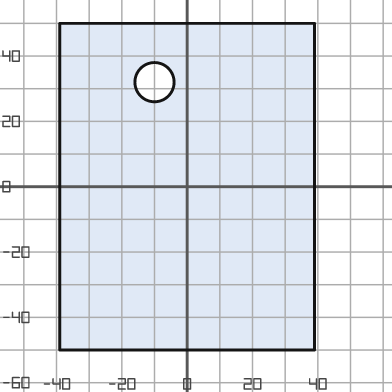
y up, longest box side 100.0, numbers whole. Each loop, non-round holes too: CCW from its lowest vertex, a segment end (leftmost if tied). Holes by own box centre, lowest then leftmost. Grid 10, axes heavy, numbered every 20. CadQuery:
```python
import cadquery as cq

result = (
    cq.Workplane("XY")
    .moveTo(-39.0, -50.0)
    .lineTo(39.0, -50.0)
    .lineTo(39.0, 50.0)
    .lineTo(-39.0, 50.0)
    .close()
    .moveTo(-10.0, 32.0)
    .circle(6.0)
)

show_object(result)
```